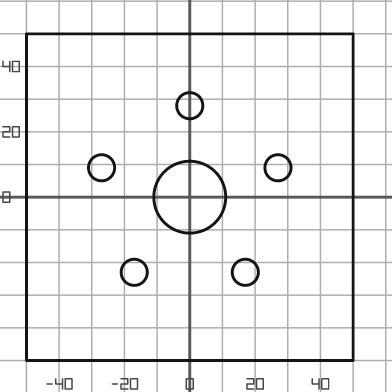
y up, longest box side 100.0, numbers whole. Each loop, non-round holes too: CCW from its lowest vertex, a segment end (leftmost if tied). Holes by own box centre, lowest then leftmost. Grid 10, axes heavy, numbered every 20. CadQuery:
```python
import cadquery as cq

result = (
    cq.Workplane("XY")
    .moveTo(-50.0, -50.0)
    .lineTo(50.0, -50.0)
    .lineTo(50.0, 50.0)
    .lineTo(-50.0, 50.0)
    .close()
    .moveTo(-17.0, -23.0)
    .circle(4.0)
    .moveTo(17.0, -23.0)
    .circle(4.0)
    .moveTo(0.0, 0.0)
    .circle(11.0)
    .moveTo(-27.0, 9.0)
    .circle(4.0)
    .moveTo(27.0, 9.0)
    .circle(4.0)
    .moveTo(0.0, 28.0)
    .circle(4.0)
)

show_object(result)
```